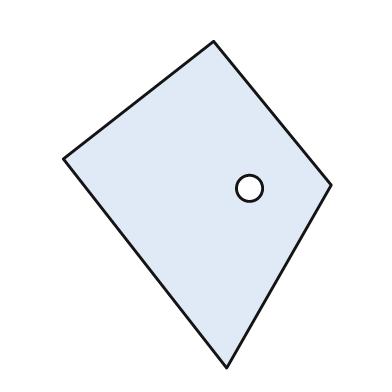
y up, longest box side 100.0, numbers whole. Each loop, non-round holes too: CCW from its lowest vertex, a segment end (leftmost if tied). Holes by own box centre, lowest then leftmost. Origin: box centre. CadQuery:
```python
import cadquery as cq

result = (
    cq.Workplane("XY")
    .moveTo(9.0, -50.0)
    .lineTo(41.0, 6.0)
    .lineTo(5.0, 50.0)
    .lineTo(-41.0, 14.0)
    .close()
    .moveTo(16.0, 5.0)
    .circle(4.0)
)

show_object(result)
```